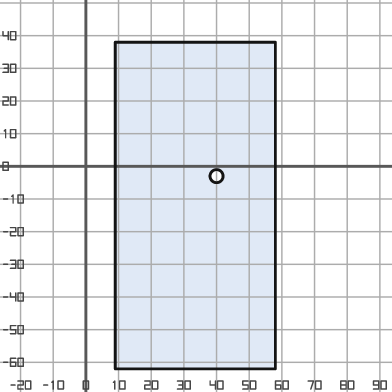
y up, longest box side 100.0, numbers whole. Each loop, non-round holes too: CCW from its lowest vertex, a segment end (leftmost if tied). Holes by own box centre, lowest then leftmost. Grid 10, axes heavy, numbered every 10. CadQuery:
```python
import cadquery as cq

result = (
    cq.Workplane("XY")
    .moveTo(9.0, -62.0)
    .lineTo(58.0, -62.0)
    .lineTo(58.0, 38.0)
    .lineTo(9.0, 38.0)
    .close()
    .moveTo(40.0, -3.0)
    .circle(2.0)
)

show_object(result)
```